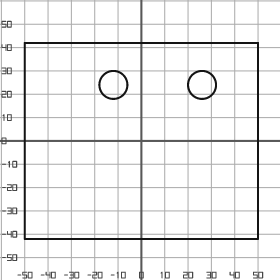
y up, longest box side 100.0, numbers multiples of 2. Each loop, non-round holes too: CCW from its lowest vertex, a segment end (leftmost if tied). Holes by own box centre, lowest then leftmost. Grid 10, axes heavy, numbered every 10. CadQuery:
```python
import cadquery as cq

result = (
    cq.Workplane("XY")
    .moveTo(-50.0, -42.0)
    .lineTo(50.0, -42.0)
    .lineTo(50.0, 42.0)
    .lineTo(-50.0, 42.0)
    .close()
    .moveTo(-12.0, 24.0)
    .circle(6.0)
    .moveTo(26.0, 24.0)
    .circle(6.0)
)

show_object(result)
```